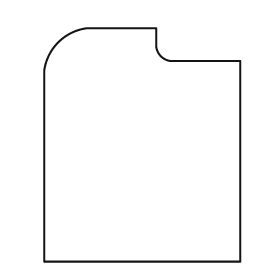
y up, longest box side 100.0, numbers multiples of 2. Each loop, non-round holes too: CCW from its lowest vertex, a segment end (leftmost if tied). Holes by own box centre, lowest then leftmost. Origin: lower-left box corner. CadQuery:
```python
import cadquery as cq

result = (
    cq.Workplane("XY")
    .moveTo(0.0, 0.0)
    .lineTo(84.0, 0.0)
    .lineTo(84.0, 86.0)
    .lineTo(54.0, 86.0)
    .threePointArc((50.0, 88.0), (48.0, 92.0))
    .lineTo(48.0, 100.0)
    .lineTo(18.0, 100.0)
    .threePointArc((6.0, 94.0), (0.0, 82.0))
    .close()
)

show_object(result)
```